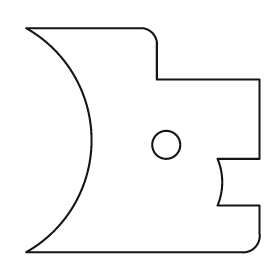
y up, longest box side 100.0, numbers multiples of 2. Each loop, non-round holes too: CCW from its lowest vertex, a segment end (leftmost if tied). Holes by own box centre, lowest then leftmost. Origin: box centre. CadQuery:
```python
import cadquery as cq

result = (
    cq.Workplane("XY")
    .moveTo(-50.0, -48.0)
    .lineTo(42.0, -48.0)
    .threePointArc((48.0, -46.0), (50.0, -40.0))
    .lineTo(50.0, -28.0)
    .lineTo(32.0, -28.0)
    .threePointArc((34.0, -18.0), (32.0, -8.0))
    .lineTo(50.0, -8.0)
    .lineTo(50.0, 26.0)
    .lineTo(6.0, 26.0)
    .lineTo(6.0, 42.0)
    .threePointArc((4.0, 46.0), (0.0, 48.0))
    .lineTo(-50.0, 48.0)
    .threePointArc((-22.0, 0.0), (-50.0, -48.0))
    .close()
    .moveTo(10.0, -2.0)
    .circle(6.0)
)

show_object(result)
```